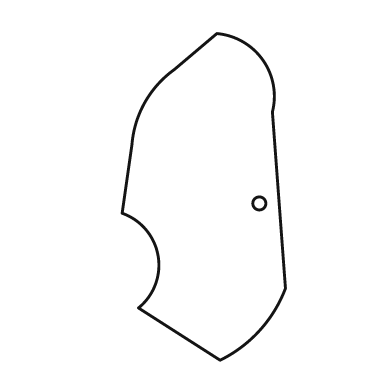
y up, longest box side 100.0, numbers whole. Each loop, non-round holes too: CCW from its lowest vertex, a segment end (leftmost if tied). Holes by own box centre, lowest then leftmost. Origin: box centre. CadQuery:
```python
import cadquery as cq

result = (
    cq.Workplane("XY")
    .moveTo(5.0, -50.0)
    .threePointArc((17.0, -41.0), (25.0, -28.0))
    .lineTo(21.0, 26.0)
    .threePointArc((18.0, 42.0), (4.0, 50.0))
    .lineTo(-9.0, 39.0)
    .threePointArc((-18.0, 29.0), (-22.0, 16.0))
    .lineTo(-25.0, -5.0)
    .threePointArc((-14.0, -18.0), (-20.0, -34.0))
    .close()
    .moveTo(17.0, -2.0)
    .circle(2.0)
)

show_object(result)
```